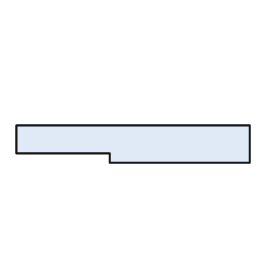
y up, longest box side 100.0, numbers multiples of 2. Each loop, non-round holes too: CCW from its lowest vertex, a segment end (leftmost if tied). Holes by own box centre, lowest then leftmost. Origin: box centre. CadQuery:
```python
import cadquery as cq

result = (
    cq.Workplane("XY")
    .moveTo(-10.0, -8.0)
    .lineTo(50.0, -8.0)
    .lineTo(50.0, 8.0)
    .lineTo(-50.0, 8.0)
    .lineTo(-50.0, -4.0)
    .lineTo(-10.0, -4.0)
    .close()
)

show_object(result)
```